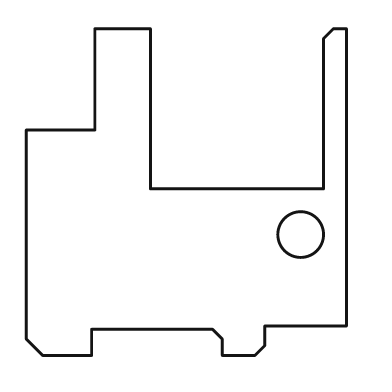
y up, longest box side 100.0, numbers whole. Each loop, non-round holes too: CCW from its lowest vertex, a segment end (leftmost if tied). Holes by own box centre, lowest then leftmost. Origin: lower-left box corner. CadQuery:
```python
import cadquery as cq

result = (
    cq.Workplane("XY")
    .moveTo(5.0, 0.0)
    .lineTo(20.0, 0.0)
    .lineTo(20.0, 8.0)
    .lineTo(57.0, 8.0)
    .lineTo(60.0, 5.0)
    .lineTo(60.0, 0.0)
    .lineTo(70.0, 0.0)
    .lineTo(73.0, 3.0)
    .lineTo(73.0, 9.0)
    .lineTo(98.0, 9.0)
    .lineTo(98.0, 100.0)
    .lineTo(94.0, 100.0)
    .lineTo(91.0, 97.0)
    .lineTo(91.0, 51.0)
    .lineTo(38.0, 51.0)
    .lineTo(38.0, 100.0)
    .lineTo(21.0, 100.0)
    .lineTo(21.0, 69.0)
    .lineTo(0.0, 69.0)
    .lineTo(0.0, 5.0)
    .close()
    .moveTo(84.0, 37.0)
    .circle(7.0)
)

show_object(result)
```